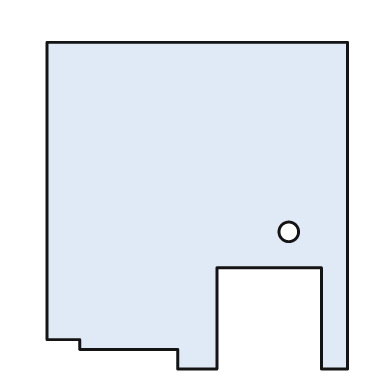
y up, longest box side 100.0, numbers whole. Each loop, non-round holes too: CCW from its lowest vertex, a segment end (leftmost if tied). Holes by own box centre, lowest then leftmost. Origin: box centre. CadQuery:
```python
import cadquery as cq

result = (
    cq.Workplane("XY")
    .moveTo(-6.0, -50.0)
    .lineTo(6.0, -50.0)
    .lineTo(6.0, -19.0)
    .lineTo(38.0, -19.0)
    .lineTo(38.0, -50.0)
    .lineTo(46.0, -50.0)
    .lineTo(46.0, 50.0)
    .lineTo(-46.0, 50.0)
    .lineTo(-46.0, -41.0)
    .lineTo(-36.0, -41.0)
    .lineTo(-36.0, -44.0)
    .lineTo(-6.0, -44.0)
    .close()
    .moveTo(28.0, -8.0)
    .circle(3.0)
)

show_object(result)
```